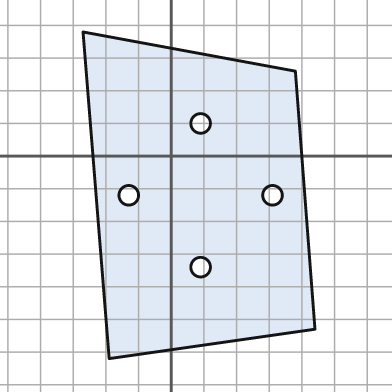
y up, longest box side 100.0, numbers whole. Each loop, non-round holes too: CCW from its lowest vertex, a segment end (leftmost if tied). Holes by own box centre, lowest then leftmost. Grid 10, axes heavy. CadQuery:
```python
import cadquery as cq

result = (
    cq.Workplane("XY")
    .moveTo(-19.0, -62.0)
    .lineTo(44.0, -53.0)
    .lineTo(38.0, 26.0)
    .lineTo(-27.0, 38.0)
    .close()
    .moveTo(9.0, -34.0)
    .circle(3.0)
    .moveTo(-13.0, -12.0)
    .circle(3.0)
    .moveTo(31.0, -12.0)
    .circle(3.0)
    .moveTo(9.0, 10.0)
    .circle(3.0)
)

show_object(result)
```